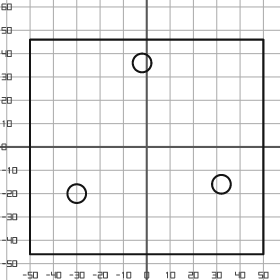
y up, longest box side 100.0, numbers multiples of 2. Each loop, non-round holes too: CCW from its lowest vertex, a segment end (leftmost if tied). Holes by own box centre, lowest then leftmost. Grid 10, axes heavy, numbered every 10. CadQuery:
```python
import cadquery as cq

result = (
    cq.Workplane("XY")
    .moveTo(-50.0, -46.0)
    .lineTo(50.0, -46.0)
    .lineTo(50.0, 46.0)
    .lineTo(-50.0, 46.0)
    .close()
    .moveTo(-30.0, -20.0)
    .circle(4.0)
    .moveTo(32.0, -16.0)
    .circle(4.0)
    .moveTo(-2.0, 36.0)
    .circle(4.0)
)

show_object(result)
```